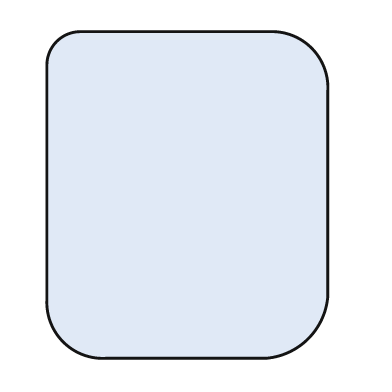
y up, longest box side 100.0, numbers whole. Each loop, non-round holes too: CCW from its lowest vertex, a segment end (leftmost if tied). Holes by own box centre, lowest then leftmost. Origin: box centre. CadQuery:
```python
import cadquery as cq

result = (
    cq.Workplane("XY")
    .moveTo(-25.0, -50.0)
    .lineTo(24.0, -50.0)
    .threePointArc((37.0, -44.0), (43.0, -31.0))
    .lineTo(43.0, 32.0)
    .threePointArc((38.0, 45.0), (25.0, 50.0))
    .lineTo(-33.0, 50.0)
    .threePointArc((-40.0, 47.0), (-43.0, 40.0))
    .lineTo(-43.0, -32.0)
    .threePointArc((-38.0, -45.0), (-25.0, -50.0))
    .close()
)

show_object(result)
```